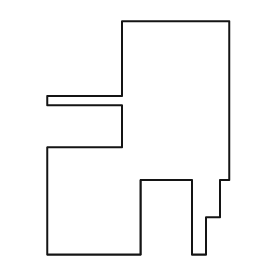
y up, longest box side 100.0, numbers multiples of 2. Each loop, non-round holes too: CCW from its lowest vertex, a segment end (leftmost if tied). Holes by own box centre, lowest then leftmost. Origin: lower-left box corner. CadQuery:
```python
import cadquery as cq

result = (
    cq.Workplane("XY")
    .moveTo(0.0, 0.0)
    .lineTo(40.0, 0.0)
    .lineTo(40.0, 32.0)
    .lineTo(62.0, 32.0)
    .lineTo(62.0, 0.0)
    .lineTo(68.0, 0.0)
    .lineTo(68.0, 16.0)
    .lineTo(74.0, 16.0)
    .lineTo(74.0, 32.0)
    .lineTo(78.0, 32.0)
    .lineTo(78.0, 100.0)
    .lineTo(32.0, 100.0)
    .lineTo(32.0, 68.0)
    .lineTo(0.0, 68.0)
    .lineTo(0.0, 64.0)
    .lineTo(32.0, 64.0)
    .lineTo(32.0, 46.0)
    .lineTo(0.0, 46.0)
    .close()
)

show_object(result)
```